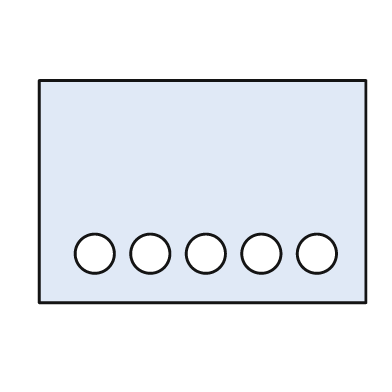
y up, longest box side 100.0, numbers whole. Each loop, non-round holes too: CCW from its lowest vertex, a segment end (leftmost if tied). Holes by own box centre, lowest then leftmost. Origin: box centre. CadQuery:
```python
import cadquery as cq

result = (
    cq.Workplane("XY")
    .moveTo(-50.0, -34.0)
    .lineTo(50.0, -34.0)
    .lineTo(50.0, 34.0)
    .lineTo(-50.0, 34.0)
    .close()
    .moveTo(-33.0, -19.0)
    .circle(6.0)
    .moveTo(-16.0, -19.0)
    .circle(6.0)
    .moveTo(1.0, -19.0)
    .circle(6.0)
    .moveTo(18.0, -19.0)
    .circle(6.0)
    .moveTo(35.0, -19.0)
    .circle(6.0)
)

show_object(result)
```